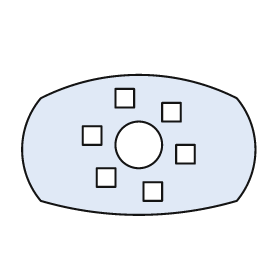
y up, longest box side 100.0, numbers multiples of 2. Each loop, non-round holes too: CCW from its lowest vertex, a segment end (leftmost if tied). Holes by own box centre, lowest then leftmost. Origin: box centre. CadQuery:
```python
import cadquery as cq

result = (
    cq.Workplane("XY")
    .moveTo(-42.0, -24.0)
    .threePointArc((0.0, -30.0), (42.0, -24.0))
    .threePointArc((50.0, -2.0), (42.0, 20.0))
    .threePointArc((0.0, 30.0), (-42.0, 20.0))
    .threePointArc((-50.0, -2.0), (-42.0, -24.0))
    .close()
    .moveTo(2.0, -24.0)
    .lineTo(10.0, -24.0)
    .lineTo(10.0, -16.0)
    .lineTo(2.0, -16.0)
    .close()
    .moveTo(-18.0, -18.0)
    .lineTo(-10.0, -18.0)
    .lineTo(-10.0, -10.0)
    .lineTo(-18.0, -10.0)
    .close()
    .moveTo(16.0, -8.0)
    .lineTo(24.0, -8.0)
    .lineTo(24.0, 0.0)
    .lineTo(16.0, 0.0)
    .close()
    .moveTo(0.0, 0.0)
    .circle(10.0)
    .moveTo(-24.0, 0.0)
    .lineTo(-16.0, 0.0)
    .lineTo(-16.0, 8.0)
    .lineTo(-24.0, 8.0)
    .close()
    .moveTo(10.0, 10.0)
    .lineTo(18.0, 10.0)
    .lineTo(18.0, 18.0)
    .lineTo(10.0, 18.0)
    .close()
    .moveTo(-10.0, 16.0)
    .lineTo(-2.0, 16.0)
    .lineTo(-2.0, 24.0)
    .lineTo(-10.0, 24.0)
    .close()
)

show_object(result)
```